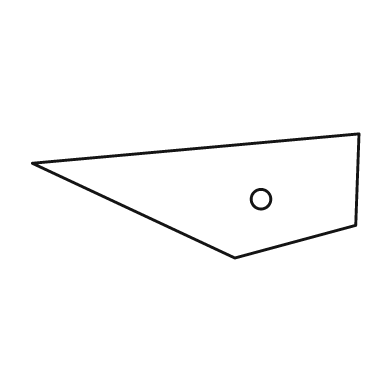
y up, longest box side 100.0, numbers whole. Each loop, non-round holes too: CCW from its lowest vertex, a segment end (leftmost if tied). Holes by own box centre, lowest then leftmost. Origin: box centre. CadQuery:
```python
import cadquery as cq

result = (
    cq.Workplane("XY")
    .moveTo(12.0, -19.0)
    .lineTo(49.0, -9.0)
    .lineTo(50.0, 19.0)
    .lineTo(-50.0, 10.0)
    .close()
    .moveTo(20.0, -1.0)
    .circle(3.0)
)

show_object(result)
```